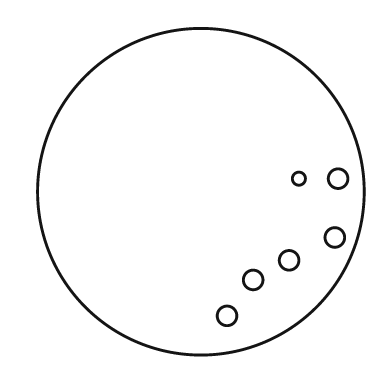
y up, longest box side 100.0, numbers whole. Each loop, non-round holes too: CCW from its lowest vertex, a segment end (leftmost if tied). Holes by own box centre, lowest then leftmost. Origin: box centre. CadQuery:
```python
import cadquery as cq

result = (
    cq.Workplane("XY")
    .moveTo(0.0, 0.0)
    .circle(50.0)
    .moveTo(8.0, -38.0)
    .circle(3.0)
    .moveTo(16.0, -27.0)
    .circle(3.0)
    .moveTo(27.0, -21.0)
    .circle(3.0)
    .moveTo(41.0, -14.0)
    .circle(3.0)
    .moveTo(30.0, 4.0)
    .circle(2.0)
    .moveTo(42.0, 4.0)
    .circle(3.0)
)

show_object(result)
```